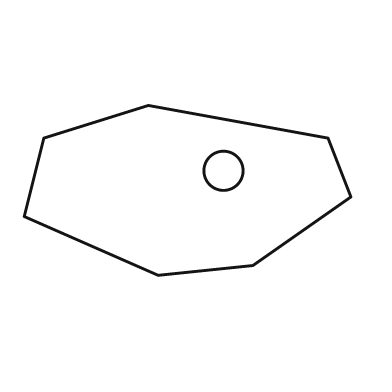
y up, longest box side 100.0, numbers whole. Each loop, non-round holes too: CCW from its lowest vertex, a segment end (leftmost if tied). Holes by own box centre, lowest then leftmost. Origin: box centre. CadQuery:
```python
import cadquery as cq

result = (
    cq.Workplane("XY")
    .moveTo(-9.0, -26.0)
    .lineTo(20.0, -23.0)
    .lineTo(50.0, -2.0)
    .lineTo(43.0, 16.0)
    .lineTo(-12.0, 26.0)
    .lineTo(-44.0, 16.0)
    .lineTo(-50.0, -8.0)
    .close()
    .moveTo(11.0, 6.0)
    .circle(6.0)
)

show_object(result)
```